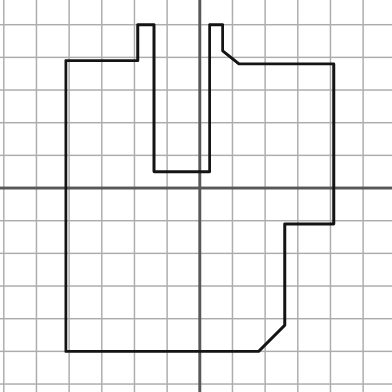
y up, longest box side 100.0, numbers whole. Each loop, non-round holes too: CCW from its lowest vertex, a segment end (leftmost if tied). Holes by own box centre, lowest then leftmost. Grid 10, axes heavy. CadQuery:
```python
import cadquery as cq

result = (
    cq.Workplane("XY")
    .moveTo(-41.0, -50.0)
    .lineTo(18.0, -50.0)
    .lineTo(26.0, -42.0)
    .lineTo(26.0, -11.0)
    .lineTo(41.0, -11.0)
    .lineTo(41.0, 38.0)
    .lineTo(12.0, 38.0)
    .lineTo(7.0, 42.0)
    .lineTo(7.0, 50.0)
    .lineTo(3.0, 50.0)
    .lineTo(3.0, 5.0)
    .lineTo(-14.0, 5.0)
    .lineTo(-14.0, 50.0)
    .lineTo(-19.0, 50.0)
    .lineTo(-19.0, 39.0)
    .lineTo(-41.0, 39.0)
    .close()
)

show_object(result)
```